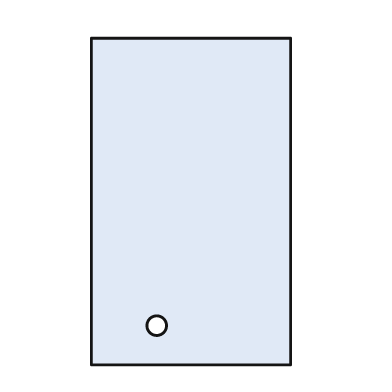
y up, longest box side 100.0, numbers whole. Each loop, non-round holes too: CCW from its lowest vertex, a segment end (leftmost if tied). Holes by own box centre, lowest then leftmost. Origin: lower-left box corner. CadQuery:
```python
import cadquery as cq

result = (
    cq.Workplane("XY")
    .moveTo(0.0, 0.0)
    .lineTo(61.0, 0.0)
    .lineTo(61.0, 100.0)
    .lineTo(0.0, 100.0)
    .close()
    .moveTo(20.0, 12.0)
    .circle(3.0)
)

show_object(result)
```